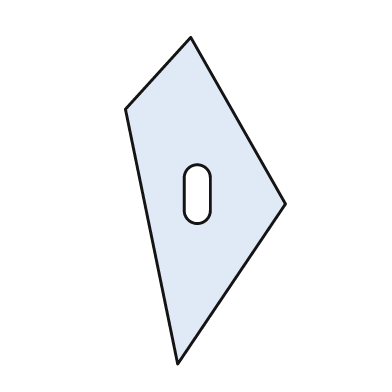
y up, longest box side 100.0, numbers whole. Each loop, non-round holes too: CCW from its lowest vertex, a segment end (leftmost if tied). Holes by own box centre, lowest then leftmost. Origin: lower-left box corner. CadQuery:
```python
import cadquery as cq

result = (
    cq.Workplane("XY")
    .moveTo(16.0, 0.0)
    .lineTo(49.0, 49.0)
    .lineTo(20.0, 100.0)
    .lineTo(0.0, 78.0)
    .close()
    .moveTo(18.0, 47.0)
    .threePointArc((22.0, 43.0), (26.0, 47.0))
    .lineTo(26.0, 57.0)
    .threePointArc((22.0, 61.0), (18.0, 57.0))
    .close()
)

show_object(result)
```